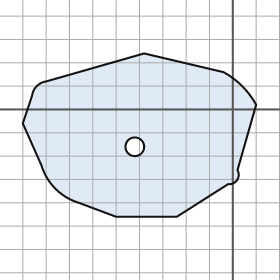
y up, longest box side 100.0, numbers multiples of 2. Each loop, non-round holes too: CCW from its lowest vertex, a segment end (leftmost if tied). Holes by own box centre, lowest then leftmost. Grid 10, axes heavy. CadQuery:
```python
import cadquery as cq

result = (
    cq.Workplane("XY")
    .moveTo(-50.0, -46.0)
    .lineTo(-24.0, -46.0)
    .lineTo(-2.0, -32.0)
    .threePointArc((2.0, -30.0), (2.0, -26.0))
    .lineTo(10.0, 2.0)
    .threePointArc((4.0, 10.0), (-4.0, 16.0))
    .lineTo(-38.0, 24.0)
    .lineTo(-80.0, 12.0)
    .threePointArc((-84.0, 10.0), (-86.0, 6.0))
    .lineTo(-90.0, -6.0)
    .lineTo(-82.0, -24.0)
    .threePointArc((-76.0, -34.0), (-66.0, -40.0))
    .close()
    .moveTo(-42.0, -16.0)
    .circle(4.0)
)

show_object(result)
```